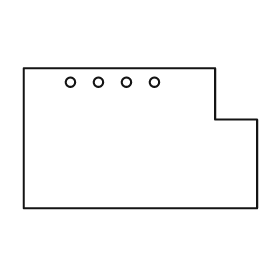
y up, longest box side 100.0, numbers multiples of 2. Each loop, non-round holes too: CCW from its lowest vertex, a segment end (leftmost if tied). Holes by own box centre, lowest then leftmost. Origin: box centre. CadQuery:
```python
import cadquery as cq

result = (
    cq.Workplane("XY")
    .moveTo(-50.0, -30.0)
    .lineTo(50.0, -30.0)
    .lineTo(50.0, 8.0)
    .lineTo(32.0, 8.0)
    .lineTo(32.0, 30.0)
    .lineTo(-50.0, 30.0)
    .close()
    .moveTo(-30.0, 24.0)
    .circle(2.0)
    .moveTo(-18.0, 24.0)
    .circle(2.0)
    .moveTo(-6.0, 24.0)
    .circle(2.0)
    .moveTo(6.0, 24.0)
    .circle(2.0)
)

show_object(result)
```